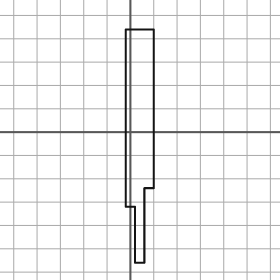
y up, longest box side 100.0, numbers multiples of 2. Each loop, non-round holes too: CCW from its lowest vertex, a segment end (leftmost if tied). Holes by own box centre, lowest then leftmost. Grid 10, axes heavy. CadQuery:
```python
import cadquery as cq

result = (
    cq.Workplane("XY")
    .moveTo(2.0, -56.0)
    .lineTo(6.0, -56.0)
    .lineTo(6.0, -24.0)
    .lineTo(10.0, -24.0)
    .lineTo(10.0, 44.0)
    .lineTo(-2.0, 44.0)
    .lineTo(-2.0, -32.0)
    .lineTo(2.0, -32.0)
    .close()
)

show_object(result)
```